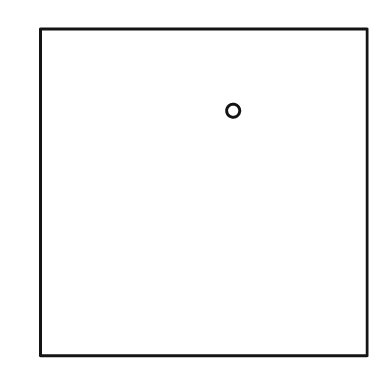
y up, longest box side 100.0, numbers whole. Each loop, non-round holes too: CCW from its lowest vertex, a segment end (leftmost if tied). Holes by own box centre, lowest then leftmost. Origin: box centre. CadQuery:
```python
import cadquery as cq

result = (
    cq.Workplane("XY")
    .moveTo(-50.0, -50.0)
    .lineTo(50.0, -50.0)
    .lineTo(50.0, 50.0)
    .lineTo(-50.0, 50.0)
    .close()
    .moveTo(9.0, 25.0)
    .circle(2.0)
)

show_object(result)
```